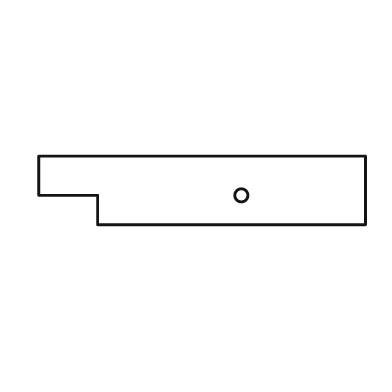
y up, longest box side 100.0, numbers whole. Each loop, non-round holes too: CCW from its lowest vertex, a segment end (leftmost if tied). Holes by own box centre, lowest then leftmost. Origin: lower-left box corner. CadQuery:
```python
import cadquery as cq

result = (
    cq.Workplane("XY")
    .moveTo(18.0, 0.0)
    .lineTo(100.0, 0.0)
    .lineTo(100.0, 21.0)
    .lineTo(0.0, 21.0)
    .lineTo(0.0, 9.0)
    .lineTo(18.0, 9.0)
    .close()
    .moveTo(62.0, 9.0)
    .circle(2.0)
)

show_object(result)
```